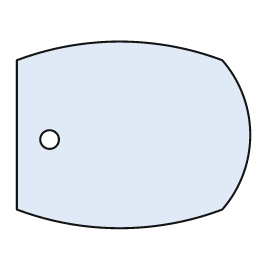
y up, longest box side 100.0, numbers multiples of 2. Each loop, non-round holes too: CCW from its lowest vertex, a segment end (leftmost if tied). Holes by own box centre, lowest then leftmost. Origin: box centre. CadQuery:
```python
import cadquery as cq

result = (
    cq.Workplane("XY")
    .moveTo(-50.0, -32.0)
    .threePointArc((-6.0, -40.0), (38.0, -32.0))
    .threePointArc((50.0, 0.0), (38.0, 32.0))
    .threePointArc((-6.0, 40.0), (-50.0, 32.0))
    .close()
    .moveTo(-36.0, -2.0)
    .circle(4.0)
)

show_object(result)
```